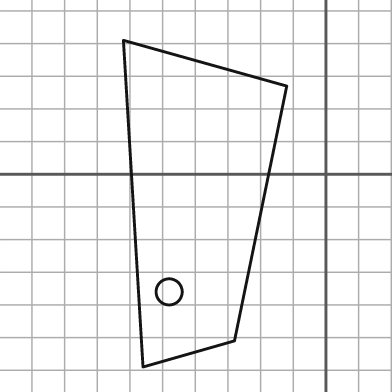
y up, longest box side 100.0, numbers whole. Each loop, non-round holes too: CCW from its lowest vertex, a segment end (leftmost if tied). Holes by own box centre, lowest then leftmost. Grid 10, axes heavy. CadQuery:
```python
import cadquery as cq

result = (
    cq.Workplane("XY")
    .moveTo(-56.0, -59.0)
    .lineTo(-28.0, -51.0)
    .lineTo(-12.0, 27.0)
    .lineTo(-62.0, 41.0)
    .close()
    .moveTo(-48.0, -36.0)
    .circle(4.0)
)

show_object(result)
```